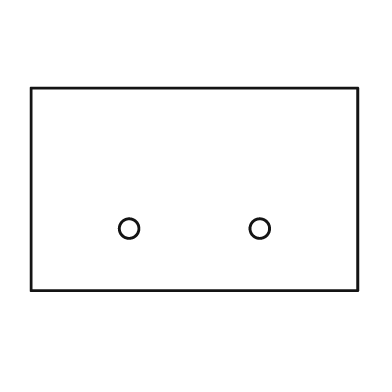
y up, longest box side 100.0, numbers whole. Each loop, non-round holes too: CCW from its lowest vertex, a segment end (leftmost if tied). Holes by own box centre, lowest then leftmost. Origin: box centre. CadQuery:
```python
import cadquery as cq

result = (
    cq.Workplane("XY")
    .moveTo(-50.0, -31.0)
    .lineTo(50.0, -31.0)
    .lineTo(50.0, 31.0)
    .lineTo(-50.0, 31.0)
    .close()
    .moveTo(-20.0, -12.0)
    .circle(3.0)
    .moveTo(20.0, -12.0)
    .circle(3.0)
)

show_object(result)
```